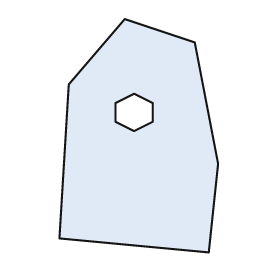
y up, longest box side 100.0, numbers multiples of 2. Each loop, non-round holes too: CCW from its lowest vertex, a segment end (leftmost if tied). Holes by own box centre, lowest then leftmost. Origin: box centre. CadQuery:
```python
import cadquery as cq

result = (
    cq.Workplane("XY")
    .moveTo(30.0, -50.0)
    .lineTo(34.0, -12.0)
    .lineTo(24.0, 40.0)
    .lineTo(-6.0, 50.0)
    .lineTo(-30.0, 22.0)
    .lineTo(-34.0, -44.0)
    .close()
    .moveTo(-2.0, 2.0)
    .lineTo(6.0, 6.0)
    .lineTo(6.0, 14.0)
    .lineTo(-2.0, 18.0)
    .lineTo(-10.0, 14.0)
    .lineTo(-10.0, 6.0)
    .close()
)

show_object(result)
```